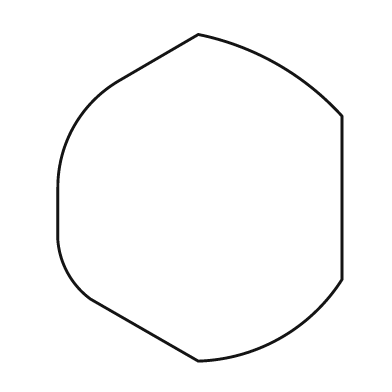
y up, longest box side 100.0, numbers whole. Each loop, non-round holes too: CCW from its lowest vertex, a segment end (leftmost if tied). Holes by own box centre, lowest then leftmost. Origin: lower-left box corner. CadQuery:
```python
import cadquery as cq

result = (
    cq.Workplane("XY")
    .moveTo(43.0, 0.0)
    .threePointArc((68.0, 7.0), (87.0, 25.0))
    .lineTo(87.0, 75.0)
    .threePointArc((67.0, 91.0), (43.0, 100.0))
    .lineTo(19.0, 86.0)
    .threePointArc((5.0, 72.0), (0.0, 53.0))
    .lineTo(0.0, 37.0)
    .threePointArc((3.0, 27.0), (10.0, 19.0))
    .close()
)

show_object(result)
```